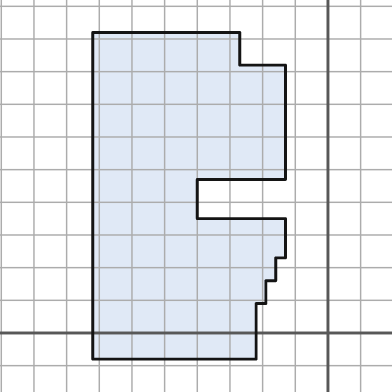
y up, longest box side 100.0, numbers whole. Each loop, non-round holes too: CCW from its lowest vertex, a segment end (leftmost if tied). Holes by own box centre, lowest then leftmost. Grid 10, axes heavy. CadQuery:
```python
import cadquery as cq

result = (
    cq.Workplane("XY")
    .moveTo(-72.0, -8.0)
    .lineTo(-22.0, -8.0)
    .lineTo(-22.0, 9.0)
    .lineTo(-19.0, 9.0)
    .lineTo(-19.0, 16.0)
    .lineTo(-16.0, 16.0)
    .lineTo(-16.0, 23.0)
    .lineTo(-13.0, 23.0)
    .lineTo(-13.0, 35.0)
    .lineTo(-40.0, 35.0)
    .lineTo(-40.0, 47.0)
    .lineTo(-13.0, 47.0)
    .lineTo(-13.0, 82.0)
    .lineTo(-27.0, 82.0)
    .lineTo(-27.0, 92.0)
    .lineTo(-72.0, 92.0)
    .close()
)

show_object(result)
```